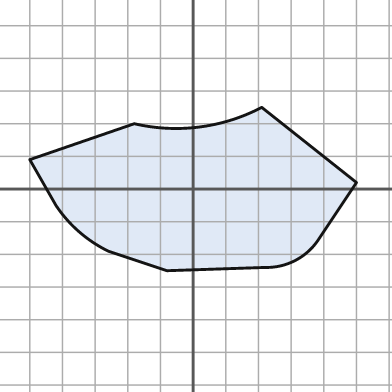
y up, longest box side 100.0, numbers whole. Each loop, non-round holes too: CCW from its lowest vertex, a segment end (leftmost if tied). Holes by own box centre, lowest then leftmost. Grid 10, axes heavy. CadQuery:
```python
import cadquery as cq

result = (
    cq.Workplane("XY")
    .moveTo(-8.0, -25.0)
    .lineTo(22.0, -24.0)
    .threePointArc((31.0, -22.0), (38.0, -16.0))
    .lineTo(50.0, 2.0)
    .lineTo(21.0, 25.0)
    .threePointArc((2.0, 19.0), (-18.0, 20.0))
    .lineTo(-50.0, 9.0)
    .lineTo(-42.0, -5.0)
    .threePointArc((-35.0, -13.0), (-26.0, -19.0))
    .close()
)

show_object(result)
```